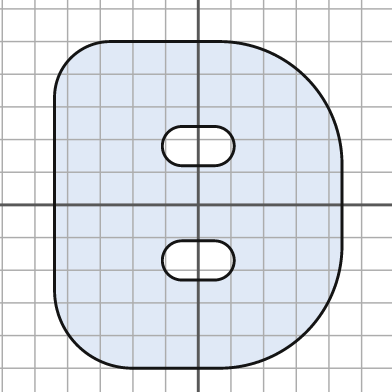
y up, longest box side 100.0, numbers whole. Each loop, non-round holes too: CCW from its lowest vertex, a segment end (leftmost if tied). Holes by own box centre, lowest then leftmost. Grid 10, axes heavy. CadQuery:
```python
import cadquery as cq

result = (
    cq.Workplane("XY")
    .moveTo(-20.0, -50.0)
    .lineTo(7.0, -50.0)
    .threePointArc((33.0, -39.0), (44.0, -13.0))
    .lineTo(44.0, 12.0)
    .threePointArc((33.0, 39.0), (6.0, 50.0))
    .lineTo(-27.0, 50.0)
    .threePointArc((-39.0, 45.0), (-44.0, 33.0))
    .lineTo(-44.0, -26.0)
    .threePointArc((-37.0, -43.0), (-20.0, -50.0))
    .close()
    .moveTo(-5.0, -23.0)
    .lineTo(5.0, -23.0)
    .threePointArc((11.0, -17.0), (5.0, -11.0))
    .lineTo(-5.0, -11.0)
    .threePointArc((-11.0, -17.0), (-5.0, -23.0))
    .close()
    .moveTo(-5.0, 12.0)
    .lineTo(5.0, 12.0)
    .threePointArc((11.0, 18.0), (5.0, 24.0))
    .lineTo(-5.0, 24.0)
    .threePointArc((-11.0, 18.0), (-5.0, 12.0))
    .close()
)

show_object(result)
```